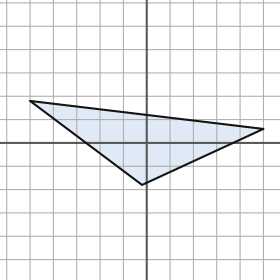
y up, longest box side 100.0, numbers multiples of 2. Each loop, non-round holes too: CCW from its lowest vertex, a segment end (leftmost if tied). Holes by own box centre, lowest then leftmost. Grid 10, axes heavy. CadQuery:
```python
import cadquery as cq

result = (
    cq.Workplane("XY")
    .moveTo(-2.0, -18.0)
    .lineTo(50.0, 6.0)
    .lineTo(-50.0, 18.0)
    .close()
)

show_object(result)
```